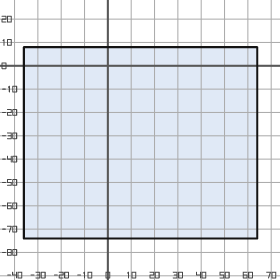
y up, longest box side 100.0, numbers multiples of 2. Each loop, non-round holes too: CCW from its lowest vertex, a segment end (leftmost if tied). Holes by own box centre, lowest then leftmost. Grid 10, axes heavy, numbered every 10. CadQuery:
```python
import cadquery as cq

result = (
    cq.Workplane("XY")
    .moveTo(-36.0, -74.0)
    .lineTo(64.0, -74.0)
    .lineTo(64.0, 8.0)
    .lineTo(-36.0, 8.0)
    .close()
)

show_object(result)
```